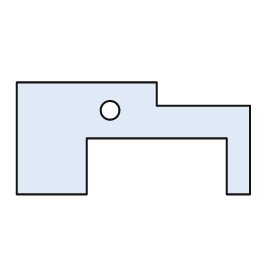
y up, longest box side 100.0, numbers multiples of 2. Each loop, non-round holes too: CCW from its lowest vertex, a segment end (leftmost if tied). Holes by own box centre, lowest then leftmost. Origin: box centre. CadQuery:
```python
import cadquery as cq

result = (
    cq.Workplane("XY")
    .moveTo(-50.0, -24.0)
    .lineTo(-20.0, -24.0)
    .lineTo(-20.0, 0.0)
    .lineTo(40.0, 0.0)
    .lineTo(40.0, -24.0)
    .lineTo(50.0, -24.0)
    .lineTo(50.0, 14.0)
    .lineTo(10.0, 14.0)
    .lineTo(10.0, 24.0)
    .lineTo(-50.0, 24.0)
    .close()
    .moveTo(-10.0, 12.0)
    .circle(4.0)
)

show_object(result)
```